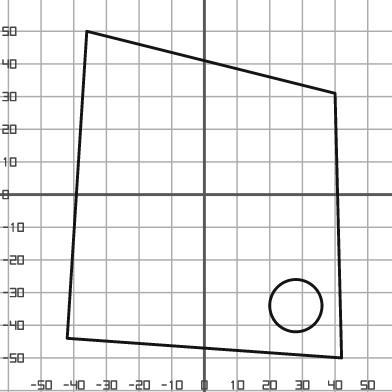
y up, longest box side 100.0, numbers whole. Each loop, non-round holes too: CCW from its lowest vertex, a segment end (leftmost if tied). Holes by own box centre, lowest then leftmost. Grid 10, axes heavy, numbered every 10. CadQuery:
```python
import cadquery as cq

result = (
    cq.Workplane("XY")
    .moveTo(42.0, -50.0)
    .lineTo(40.0, 31.0)
    .lineTo(-36.0, 50.0)
    .lineTo(-42.0, -44.0)
    .close()
    .moveTo(28.0, -34.0)
    .circle(8.0)
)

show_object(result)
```